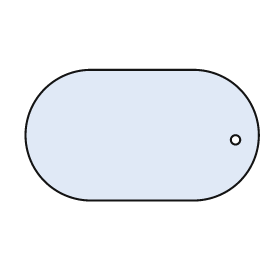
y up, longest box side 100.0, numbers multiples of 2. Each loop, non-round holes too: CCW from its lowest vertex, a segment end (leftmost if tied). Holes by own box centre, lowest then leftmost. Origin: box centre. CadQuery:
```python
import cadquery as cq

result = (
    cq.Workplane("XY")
    .moveTo(-22.0, -28.0)
    .lineTo(22.0, -28.0)
    .threePointArc((50.0, 0.0), (22.0, 28.0))
    .lineTo(-22.0, 28.0)
    .threePointArc((-50.0, 0.0), (-22.0, -28.0))
    .close()
    .moveTo(40.0, -2.0)
    .circle(2.0)
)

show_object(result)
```